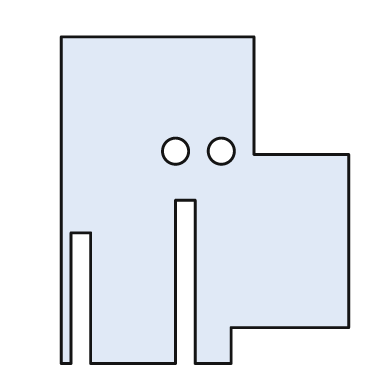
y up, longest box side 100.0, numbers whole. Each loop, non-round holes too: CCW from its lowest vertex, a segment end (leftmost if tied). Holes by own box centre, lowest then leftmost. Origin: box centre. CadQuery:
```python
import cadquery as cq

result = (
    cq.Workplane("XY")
    .moveTo(-44.0, -50.0)
    .lineTo(-41.0, -50.0)
    .lineTo(-41.0, -10.0)
    .lineTo(-35.0, -10.0)
    .lineTo(-35.0, -50.0)
    .lineTo(-9.0, -50.0)
    .lineTo(-9.0, 0.0)
    .lineTo(-3.0, 0.0)
    .lineTo(-3.0, -50.0)
    .lineTo(8.0, -50.0)
    .lineTo(8.0, -39.0)
    .lineTo(44.0, -39.0)
    .lineTo(44.0, 14.0)
    .lineTo(15.0, 14.0)
    .lineTo(15.0, 50.0)
    .lineTo(-44.0, 50.0)
    .close()
    .moveTo(-9.0, 15.0)
    .circle(4.0)
    .moveTo(5.0, 15.0)
    .circle(4.0)
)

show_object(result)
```